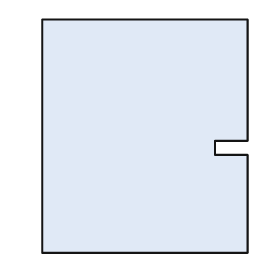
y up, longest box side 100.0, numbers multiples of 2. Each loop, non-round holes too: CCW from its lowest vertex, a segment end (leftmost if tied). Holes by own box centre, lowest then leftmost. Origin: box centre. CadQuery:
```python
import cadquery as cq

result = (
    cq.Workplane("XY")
    .moveTo(-44.0, -50.0)
    .lineTo(44.0, -50.0)
    .lineTo(44.0, -8.0)
    .lineTo(30.0, -8.0)
    .lineTo(30.0, -2.0)
    .lineTo(44.0, -2.0)
    .lineTo(44.0, 50.0)
    .lineTo(-44.0, 50.0)
    .close()
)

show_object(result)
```